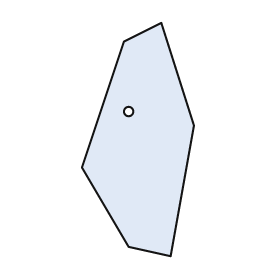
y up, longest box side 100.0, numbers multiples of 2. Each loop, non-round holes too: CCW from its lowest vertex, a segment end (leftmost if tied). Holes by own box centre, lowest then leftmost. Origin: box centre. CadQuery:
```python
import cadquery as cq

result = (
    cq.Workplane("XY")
    .moveTo(14.0, -50.0)
    .lineTo(24.0, 6.0)
    .lineTo(10.0, 50.0)
    .lineTo(-6.0, 42.0)
    .lineTo(-24.0, -12.0)
    .lineTo(-4.0, -46.0)
    .close()
    .moveTo(-4.0, 12.0)
    .circle(2.0)
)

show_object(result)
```